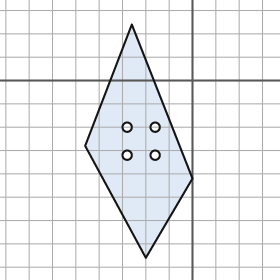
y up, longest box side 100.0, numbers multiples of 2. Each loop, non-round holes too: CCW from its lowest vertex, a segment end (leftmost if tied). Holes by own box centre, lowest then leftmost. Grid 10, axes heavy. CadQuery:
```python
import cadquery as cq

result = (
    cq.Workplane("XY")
    .moveTo(-20.0, -76.0)
    .lineTo(0.0, -42.0)
    .lineTo(-26.0, 24.0)
    .lineTo(-46.0, -28.0)
    .close()
    .moveTo(-28.0, -32.0)
    .circle(2.0)
    .moveTo(-16.0, -32.0)
    .circle(2.0)
    .moveTo(-28.0, -20.0)
    .circle(2.0)
    .moveTo(-16.0, -20.0)
    .circle(2.0)
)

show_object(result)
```